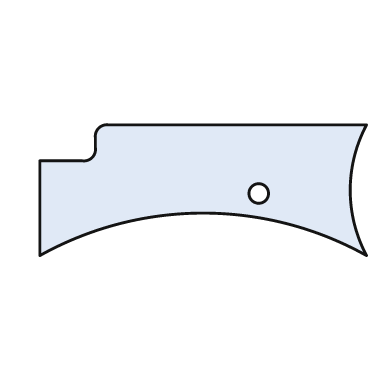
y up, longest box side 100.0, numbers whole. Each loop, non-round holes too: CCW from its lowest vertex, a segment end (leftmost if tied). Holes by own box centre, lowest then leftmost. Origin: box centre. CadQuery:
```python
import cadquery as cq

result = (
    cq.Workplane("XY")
    .moveTo(-50.0, -20.0)
    .threePointArc((0.0, -7.0), (50.0, -20.0))
    .threePointArc((45.0, 0.0), (50.0, 20.0))
    .lineTo(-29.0, 20.0)
    .threePointArc((-32.0, 19.0), (-33.0, 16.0))
    .lineTo(-33.0, 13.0)
    .threePointArc((-34.0, 10.0), (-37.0, 9.0))
    .lineTo(-50.0, 9.0)
    .close()
    .moveTo(17.0, -1.0)
    .circle(3.0)
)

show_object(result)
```